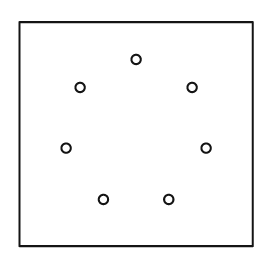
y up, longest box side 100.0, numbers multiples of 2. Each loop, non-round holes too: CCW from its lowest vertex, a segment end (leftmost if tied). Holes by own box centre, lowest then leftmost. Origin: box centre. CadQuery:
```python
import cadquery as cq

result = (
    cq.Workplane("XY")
    .moveTo(-50.0, -48.0)
    .lineTo(50.0, -48.0)
    .lineTo(50.0, 48.0)
    .lineTo(-50.0, 48.0)
    .close()
    .moveTo(-14.0, -28.0)
    .circle(2.0)
    .moveTo(14.0, -28.0)
    .circle(2.0)
    .moveTo(-30.0, -6.0)
    .circle(2.0)
    .moveTo(30.0, -6.0)
    .circle(2.0)
    .moveTo(-24.0, 20.0)
    .circle(2.0)
    .moveTo(24.0, 20.0)
    .circle(2.0)
    .moveTo(0.0, 32.0)
    .circle(2.0)
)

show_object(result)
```